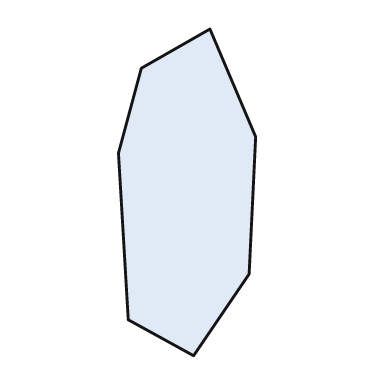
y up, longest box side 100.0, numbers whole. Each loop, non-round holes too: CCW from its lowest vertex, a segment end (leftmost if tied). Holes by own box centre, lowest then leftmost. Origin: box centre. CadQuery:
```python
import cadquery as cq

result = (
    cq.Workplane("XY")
    .moveTo(2.0, -50.0)
    .lineTo(19.0, -25.0)
    .lineTo(21.0, 17.0)
    .lineTo(7.0, 50.0)
    .lineTo(-14.0, 38.0)
    .lineTo(-21.0, 12.0)
    .lineTo(-18.0, -39.0)
    .close()
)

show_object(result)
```